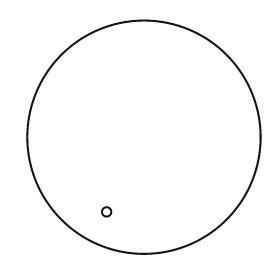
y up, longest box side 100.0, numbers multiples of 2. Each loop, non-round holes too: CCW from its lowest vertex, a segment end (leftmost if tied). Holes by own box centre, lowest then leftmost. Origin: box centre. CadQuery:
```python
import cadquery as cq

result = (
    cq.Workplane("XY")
    .moveTo(0.0, 0.0)
    .circle(50.0)
    .moveTo(-16.0, -32.0)
    .circle(2.0)
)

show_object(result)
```